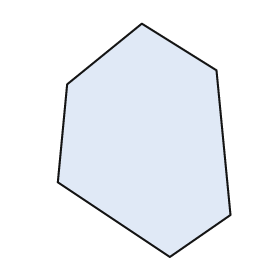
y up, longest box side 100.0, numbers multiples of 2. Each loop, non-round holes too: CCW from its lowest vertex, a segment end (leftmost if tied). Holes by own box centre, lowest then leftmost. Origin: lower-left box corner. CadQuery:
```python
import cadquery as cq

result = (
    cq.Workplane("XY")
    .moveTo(48.0, 0.0)
    .lineTo(74.0, 18.0)
    .lineTo(68.0, 80.0)
    .lineTo(36.0, 100.0)
    .lineTo(4.0, 74.0)
    .lineTo(0.0, 32.0)
    .close()
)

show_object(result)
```